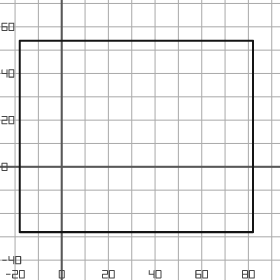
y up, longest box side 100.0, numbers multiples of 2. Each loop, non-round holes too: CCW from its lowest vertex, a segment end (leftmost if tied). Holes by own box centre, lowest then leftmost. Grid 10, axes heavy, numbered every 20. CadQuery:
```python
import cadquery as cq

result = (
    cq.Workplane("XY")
    .moveTo(-18.0, -28.0)
    .lineTo(82.0, -28.0)
    .lineTo(82.0, 54.0)
    .lineTo(-18.0, 54.0)
    .close()
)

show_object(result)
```